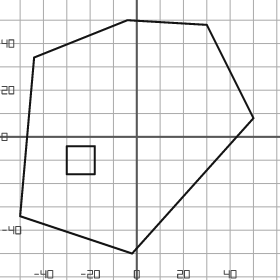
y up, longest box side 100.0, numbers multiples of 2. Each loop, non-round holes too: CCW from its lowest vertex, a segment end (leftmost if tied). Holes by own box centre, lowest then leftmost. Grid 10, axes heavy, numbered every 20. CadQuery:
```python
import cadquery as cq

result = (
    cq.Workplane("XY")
    .moveTo(-2.0, -50.0)
    .lineTo(50.0, 8.0)
    .lineTo(30.0, 48.0)
    .lineTo(-4.0, 50.0)
    .lineTo(-44.0, 34.0)
    .lineTo(-50.0, -34.0)
    .close()
    .moveTo(-30.0, -16.0)
    .lineTo(-18.0, -16.0)
    .lineTo(-18.0, -4.0)
    .lineTo(-30.0, -4.0)
    .close()
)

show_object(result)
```